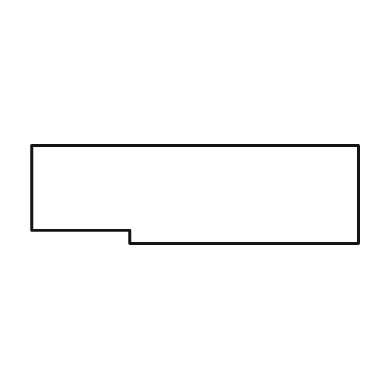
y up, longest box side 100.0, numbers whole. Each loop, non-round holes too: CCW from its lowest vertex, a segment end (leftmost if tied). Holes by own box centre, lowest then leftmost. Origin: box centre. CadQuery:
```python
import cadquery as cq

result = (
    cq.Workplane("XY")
    .moveTo(-20.0, -15.0)
    .lineTo(50.0, -15.0)
    .lineTo(50.0, 15.0)
    .lineTo(-50.0, 15.0)
    .lineTo(-50.0, -11.0)
    .lineTo(-20.0, -11.0)
    .close()
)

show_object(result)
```